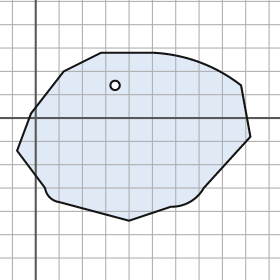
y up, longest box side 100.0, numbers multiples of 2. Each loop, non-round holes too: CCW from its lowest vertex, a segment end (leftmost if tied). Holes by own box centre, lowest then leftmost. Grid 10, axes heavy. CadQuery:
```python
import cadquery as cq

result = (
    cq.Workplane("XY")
    .moveTo(40.0, -44.0)
    .lineTo(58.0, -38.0)
    .threePointArc((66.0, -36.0), (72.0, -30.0))
    .lineTo(92.0, -8.0)
    .lineTo(88.0, 14.0)
    .threePointArc((70.0, 24.0), (50.0, 28.0))
    .lineTo(28.0, 28.0)
    .lineTo(12.0, 20.0)
    .lineTo(-2.0, 2.0)
    .lineTo(-8.0, -14.0)
    .lineTo(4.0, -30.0)
    .threePointArc((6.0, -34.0), (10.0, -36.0))
    .close()
    .moveTo(34.0, 14.0)
    .circle(2.0)
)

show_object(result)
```